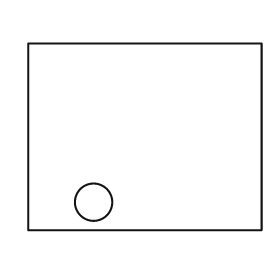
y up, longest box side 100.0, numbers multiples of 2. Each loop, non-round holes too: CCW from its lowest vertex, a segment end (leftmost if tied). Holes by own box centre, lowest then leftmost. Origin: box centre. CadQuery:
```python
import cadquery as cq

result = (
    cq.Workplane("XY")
    .moveTo(-50.0, -40.0)
    .lineTo(50.0, -40.0)
    .lineTo(50.0, 40.0)
    .lineTo(-50.0, 40.0)
    .close()
    .moveTo(-22.0, -28.0)
    .circle(8.0)
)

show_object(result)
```